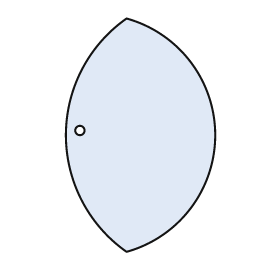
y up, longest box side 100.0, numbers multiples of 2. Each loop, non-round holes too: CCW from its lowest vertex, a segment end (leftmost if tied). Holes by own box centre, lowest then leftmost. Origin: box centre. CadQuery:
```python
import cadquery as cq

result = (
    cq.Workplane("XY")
    .moveTo(-6.0, -50.0)
    .threePointArc((32.0, 0.0), (-6.0, 50.0))
    .threePointArc((-32.0, 0.0), (-6.0, -50.0))
    .close()
    .moveTo(-26.0, 2.0)
    .circle(2.0)
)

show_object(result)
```